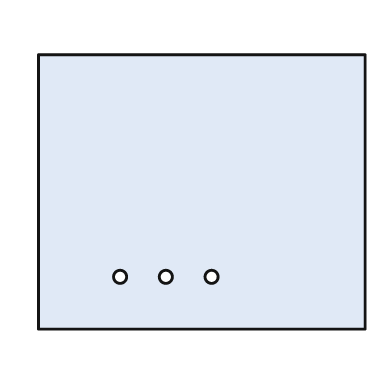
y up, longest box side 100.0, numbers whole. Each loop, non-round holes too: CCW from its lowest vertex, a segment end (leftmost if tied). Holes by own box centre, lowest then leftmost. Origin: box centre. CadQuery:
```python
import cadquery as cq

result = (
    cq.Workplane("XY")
    .moveTo(-50.0, -42.0)
    .lineTo(50.0, -42.0)
    .lineTo(50.0, 42.0)
    .lineTo(-50.0, 42.0)
    .close()
    .moveTo(-25.0, -26.0)
    .circle(2.0)
    .moveTo(-11.0, -26.0)
    .circle(2.0)
    .moveTo(3.0, -26.0)
    .circle(2.0)
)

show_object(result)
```